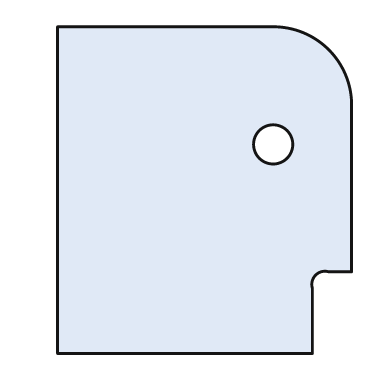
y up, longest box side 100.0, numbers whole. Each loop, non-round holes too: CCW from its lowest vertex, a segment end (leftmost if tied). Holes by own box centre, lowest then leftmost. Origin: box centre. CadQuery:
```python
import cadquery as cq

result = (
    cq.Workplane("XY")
    .moveTo(-45.0, -50.0)
    .lineTo(33.0, -50.0)
    .lineTo(33.0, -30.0)
    .threePointArc((34.0, -26.0), (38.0, -25.0))
    .lineTo(45.0, -25.0)
    .lineTo(45.0, 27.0)
    .threePointArc((38.0, 43.0), (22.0, 50.0))
    .lineTo(-45.0, 50.0)
    .close()
    .moveTo(21.0, 14.0)
    .circle(6.0)
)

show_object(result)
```